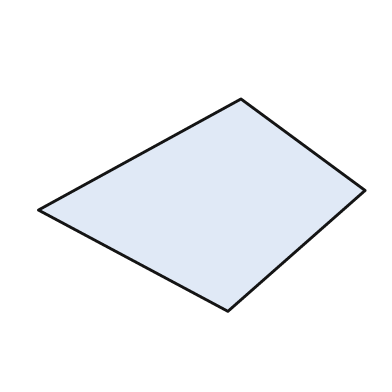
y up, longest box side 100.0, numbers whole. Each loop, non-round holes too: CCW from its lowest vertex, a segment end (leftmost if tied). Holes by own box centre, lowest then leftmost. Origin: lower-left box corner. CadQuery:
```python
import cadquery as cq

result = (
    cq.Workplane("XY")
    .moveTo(58.0, 0.0)
    .lineTo(100.0, 37.0)
    .lineTo(62.0, 65.0)
    .lineTo(0.0, 31.0)
    .close()
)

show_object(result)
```